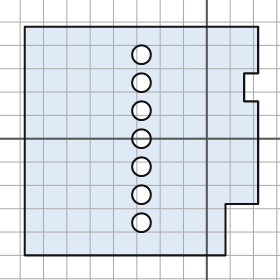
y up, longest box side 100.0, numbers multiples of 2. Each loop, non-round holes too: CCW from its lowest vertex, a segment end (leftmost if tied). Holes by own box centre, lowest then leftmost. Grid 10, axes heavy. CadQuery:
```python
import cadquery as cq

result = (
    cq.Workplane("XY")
    .moveTo(-78.0, -50.0)
    .lineTo(8.0, -50.0)
    .lineTo(8.0, -28.0)
    .lineTo(22.0, -28.0)
    .lineTo(22.0, 16.0)
    .lineTo(16.0, 16.0)
    .lineTo(16.0, 28.0)
    .lineTo(22.0, 28.0)
    .lineTo(22.0, 48.0)
    .lineTo(-78.0, 48.0)
    .close()
    .moveTo(-28.0, -36.0)
    .circle(4.0)
    .moveTo(-28.0, -24.0)
    .circle(4.0)
    .moveTo(-28.0, -12.0)
    .circle(4.0)
    .moveTo(-28.0, 0.0)
    .circle(4.0)
    .moveTo(-28.0, 12.0)
    .circle(4.0)
    .moveTo(-28.0, 24.0)
    .circle(4.0)
    .moveTo(-28.0, 36.0)
    .circle(4.0)
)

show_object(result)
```